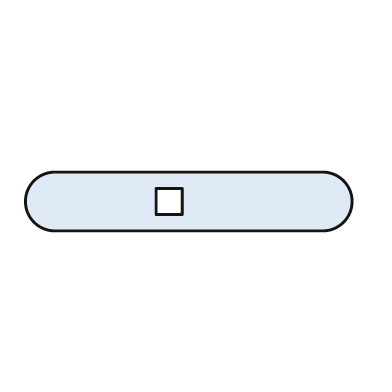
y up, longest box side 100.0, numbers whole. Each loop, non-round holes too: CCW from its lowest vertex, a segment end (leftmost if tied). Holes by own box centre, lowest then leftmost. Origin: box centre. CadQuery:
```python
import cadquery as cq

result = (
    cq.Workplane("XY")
    .moveTo(-41.0, -9.0)
    .lineTo(41.0, -9.0)
    .threePointArc((50.0, 0.0), (41.0, 9.0))
    .lineTo(-41.0, 9.0)
    .threePointArc((-50.0, 0.0), (-41.0, -9.0))
    .close()
    .moveTo(-10.0, -4.0)
    .lineTo(-2.0, -4.0)
    .lineTo(-2.0, 4.0)
    .lineTo(-10.0, 4.0)
    .close()
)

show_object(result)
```